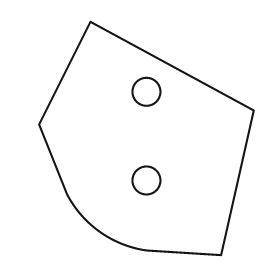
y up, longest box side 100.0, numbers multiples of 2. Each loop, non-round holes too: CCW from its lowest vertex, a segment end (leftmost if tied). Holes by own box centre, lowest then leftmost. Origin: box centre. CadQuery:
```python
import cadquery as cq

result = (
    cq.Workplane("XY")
    .moveTo(32.0, -50.0)
    .lineTo(46.0, 12.0)
    .lineTo(-24.0, 50.0)
    .lineTo(-46.0, 6.0)
    .lineTo(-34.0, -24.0)
    .threePointArc((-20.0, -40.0), (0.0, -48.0))
    .close()
    .moveTo(0.0, -18.0)
    .circle(6.0)
    .moveTo(0.0, 20.0)
    .circle(6.0)
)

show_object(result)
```